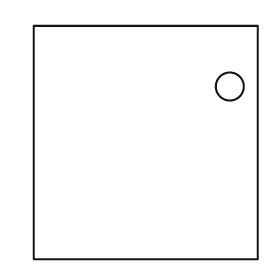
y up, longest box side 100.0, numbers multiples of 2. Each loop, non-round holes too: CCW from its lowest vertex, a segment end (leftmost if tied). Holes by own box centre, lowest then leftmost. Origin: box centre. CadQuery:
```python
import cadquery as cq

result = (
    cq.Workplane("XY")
    .moveTo(-48.0, -50.0)
    .lineTo(48.0, -50.0)
    .lineTo(48.0, 50.0)
    .lineTo(-48.0, 50.0)
    .close()
    .moveTo(36.0, 24.0)
    .circle(6.0)
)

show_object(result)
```